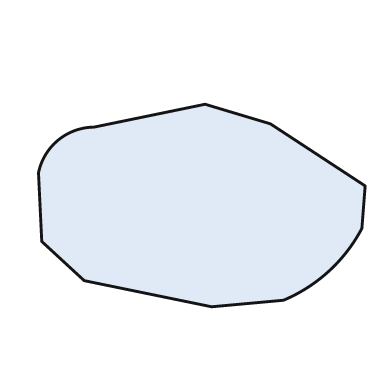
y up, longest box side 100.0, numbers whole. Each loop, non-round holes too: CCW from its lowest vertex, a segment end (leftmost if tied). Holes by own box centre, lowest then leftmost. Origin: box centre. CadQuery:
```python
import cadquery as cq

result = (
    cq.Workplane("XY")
    .moveTo(3.0, -31.0)
    .lineTo(25.0, -29.0)
    .threePointArc((39.0, -20.0), (49.0, -7.0))
    .lineTo(50.0, 6.0)
    .lineTo(21.0, 25.0)
    .lineTo(1.0, 31.0)
    .lineTo(-33.0, 24.0)
    .threePointArc((-44.0, 20.0), (-50.0, 10.0))
    .lineTo(-49.0, -11.0)
    .lineTo(-36.0, -23.0)
    .close()
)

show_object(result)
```